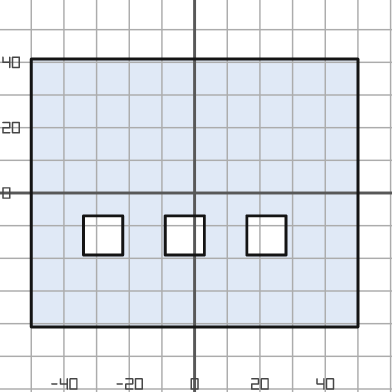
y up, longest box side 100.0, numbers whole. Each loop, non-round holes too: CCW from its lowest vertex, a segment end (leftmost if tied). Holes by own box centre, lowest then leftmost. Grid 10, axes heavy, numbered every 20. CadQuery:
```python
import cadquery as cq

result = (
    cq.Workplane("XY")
    .moveTo(-50.0, -41.0)
    .lineTo(50.0, -41.0)
    .lineTo(50.0, 41.0)
    .lineTo(-50.0, 41.0)
    .close()
    .moveTo(-34.0, -19.0)
    .lineTo(-22.0, -19.0)
    .lineTo(-22.0, -7.0)
    .lineTo(-34.0, -7.0)
    .close()
    .moveTo(-9.0, -19.0)
    .lineTo(3.0, -19.0)
    .lineTo(3.0, -7.0)
    .lineTo(-9.0, -7.0)
    .close()
    .moveTo(16.0, -19.0)
    .lineTo(28.0, -19.0)
    .lineTo(28.0, -7.0)
    .lineTo(16.0, -7.0)
    .close()
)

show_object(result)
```